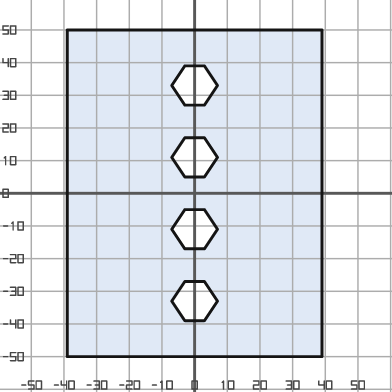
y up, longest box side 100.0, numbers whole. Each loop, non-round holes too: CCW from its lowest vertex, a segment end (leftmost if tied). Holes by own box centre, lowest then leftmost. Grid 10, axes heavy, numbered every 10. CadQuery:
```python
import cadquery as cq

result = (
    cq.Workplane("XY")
    .moveTo(-39.0, -50.0)
    .lineTo(39.0, -50.0)
    .lineTo(39.0, 50.0)
    .lineTo(-39.0, 50.0)
    .close()
    .moveTo(-3.0, -39.0)
    .lineTo(3.0, -39.0)
    .lineTo(7.0, -33.0)
    .lineTo(3.0, -27.0)
    .lineTo(-3.0, -27.0)
    .lineTo(-7.0, -33.0)
    .close()
    .moveTo(-3.0, -17.0)
    .lineTo(3.0, -17.0)
    .lineTo(7.0, -11.0)
    .lineTo(3.0, -5.0)
    .lineTo(-3.0, -5.0)
    .lineTo(-7.0, -11.0)
    .close()
    .moveTo(-3.0, 5.0)
    .lineTo(3.0, 5.0)
    .lineTo(7.0, 11.0)
    .lineTo(3.0, 17.0)
    .lineTo(-3.0, 17.0)
    .lineTo(-7.0, 11.0)
    .close()
    .moveTo(-3.0, 27.0)
    .lineTo(3.0, 27.0)
    .lineTo(7.0, 33.0)
    .lineTo(3.0, 39.0)
    .lineTo(-3.0, 39.0)
    .lineTo(-7.0, 33.0)
    .close()
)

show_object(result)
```